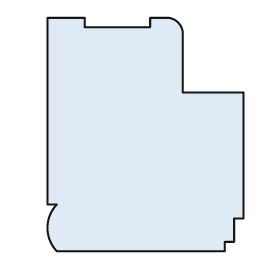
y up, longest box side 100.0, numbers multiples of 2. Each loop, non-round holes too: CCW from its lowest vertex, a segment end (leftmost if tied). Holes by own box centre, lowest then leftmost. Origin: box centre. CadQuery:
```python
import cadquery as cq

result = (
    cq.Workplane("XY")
    .moveTo(-38.0, -50.0)
    .lineTo(34.0, -50.0)
    .lineTo(34.0, -46.0)
    .lineTo(38.0, -46.0)
    .lineTo(38.0, -36.0)
    .lineTo(42.0, -36.0)
    .lineTo(42.0, 18.0)
    .lineTo(16.0, 18.0)
    .lineTo(16.0, 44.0)
    .threePointArc((14.0, 48.0), (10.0, 50.0))
    .lineTo(2.0, 50.0)
    .lineTo(2.0, 46.0)
    .lineTo(-26.0, 46.0)
    .lineTo(-26.0, 50.0)
    .lineTo(-42.0, 50.0)
    .lineTo(-42.0, -30.0)
    .lineTo(-38.0, -30.0)
    .threePointArc((-42.0, -40.0), (-38.0, -50.0))
    .close()
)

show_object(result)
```